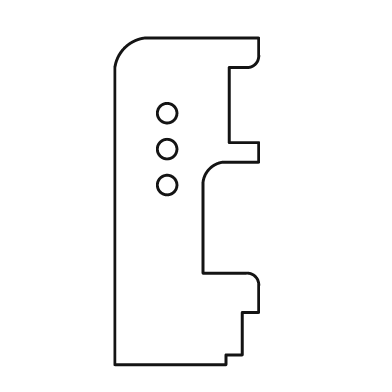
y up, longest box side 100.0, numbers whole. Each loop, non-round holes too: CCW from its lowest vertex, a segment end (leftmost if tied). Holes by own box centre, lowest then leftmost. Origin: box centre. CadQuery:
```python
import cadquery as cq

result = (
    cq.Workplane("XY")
    .moveTo(-22.0, -50.0)
    .lineTo(12.0, -50.0)
    .lineTo(12.0, -47.0)
    .lineTo(17.0, -47.0)
    .lineTo(17.0, -34.0)
    .lineTo(22.0, -34.0)
    .lineTo(22.0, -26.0)
    .threePointArc((21.0, -23.0), (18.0, -22.0))
    .lineTo(5.0, -22.0)
    .lineTo(5.0, 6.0)
    .threePointArc((7.0, 10.0), (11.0, 12.0))
    .lineTo(22.0, 12.0)
    .lineTo(22.0, 18.0)
    .lineTo(13.0, 18.0)
    .lineTo(13.0, 41.0)
    .lineTo(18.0, 41.0)
    .threePointArc((21.0, 42.0), (22.0, 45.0))
    .lineTo(22.0, 50.0)
    .lineTo(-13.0, 50.0)
    .threePointArc((-19.0, 47.0), (-22.0, 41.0))
    .close()
    .moveTo(-6.0, 5.0)
    .circle(3.0)
    .moveTo(-6.0, 16.0)
    .circle(3.0)
    .moveTo(-6.0, 27.0)
    .circle(3.0)
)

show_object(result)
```